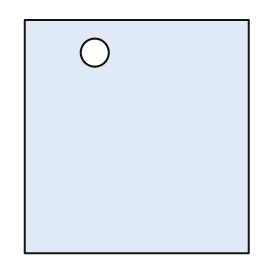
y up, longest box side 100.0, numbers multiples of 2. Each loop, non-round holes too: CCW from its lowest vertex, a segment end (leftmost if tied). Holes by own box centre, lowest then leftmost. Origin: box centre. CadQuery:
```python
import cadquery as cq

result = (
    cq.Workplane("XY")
    .moveTo(-48.0, -50.0)
    .lineTo(48.0, -50.0)
    .lineTo(48.0, 50.0)
    .lineTo(-48.0, 50.0)
    .close()
    .moveTo(-18.0, 36.0)
    .circle(6.0)
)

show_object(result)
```